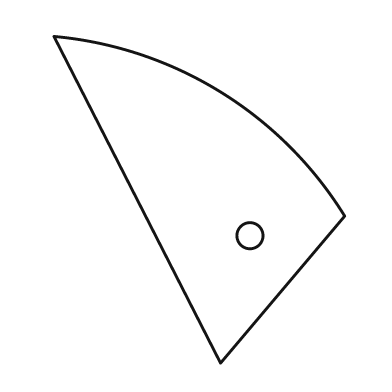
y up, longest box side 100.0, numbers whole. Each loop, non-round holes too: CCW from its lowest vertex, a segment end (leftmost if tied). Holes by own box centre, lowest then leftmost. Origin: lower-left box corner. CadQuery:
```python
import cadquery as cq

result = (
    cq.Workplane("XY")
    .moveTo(51.0, 0.0)
    .lineTo(89.0, 45.0)
    .threePointArc((51.0, 83.0), (0.0, 100.0))
    .close()
    .moveTo(60.0, 39.0)
    .circle(4.0)
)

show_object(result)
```